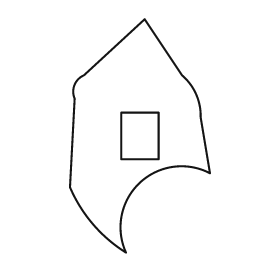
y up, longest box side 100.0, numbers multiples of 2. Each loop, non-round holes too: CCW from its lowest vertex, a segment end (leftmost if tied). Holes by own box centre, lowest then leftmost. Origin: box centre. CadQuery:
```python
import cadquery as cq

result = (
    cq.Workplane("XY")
    .moveTo(-6.0, -50.0)
    .threePointArc((0.0, -20.0), (30.0, -16.0))
    .lineTo(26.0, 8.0)
    .threePointArc((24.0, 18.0), (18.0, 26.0))
    .lineTo(2.0, 50.0)
    .lineTo(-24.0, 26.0)
    .threePointArc((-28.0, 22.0), (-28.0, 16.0))
    .lineTo(-30.0, -22.0)
    .threePointArc((-20.0, -38.0), (-6.0, -50.0))
    .close()
    .moveTo(-8.0, -10.0)
    .lineTo(8.0, -10.0)
    .lineTo(8.0, 10.0)
    .lineTo(-8.0, 10.0)
    .close()
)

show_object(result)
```